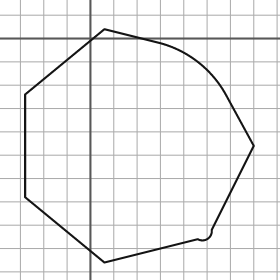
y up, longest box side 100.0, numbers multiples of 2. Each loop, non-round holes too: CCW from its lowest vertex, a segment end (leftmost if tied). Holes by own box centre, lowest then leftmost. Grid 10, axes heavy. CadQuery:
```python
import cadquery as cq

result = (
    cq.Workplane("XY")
    .moveTo(6.0, -96.0)
    .lineTo(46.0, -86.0)
    .threePointArc((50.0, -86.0), (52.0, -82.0))
    .lineTo(70.0, -46.0)
    .lineTo(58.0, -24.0)
    .threePointArc((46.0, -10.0), (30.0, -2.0))
    .lineTo(6.0, 4.0)
    .lineTo(-28.0, -24.0)
    .lineTo(-28.0, -68.0)
    .close()
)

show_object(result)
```